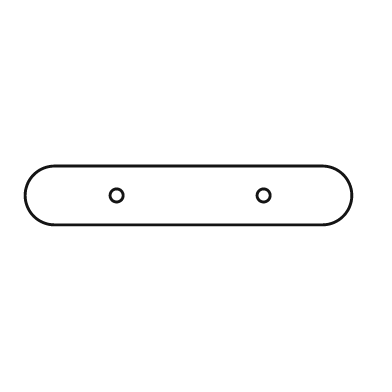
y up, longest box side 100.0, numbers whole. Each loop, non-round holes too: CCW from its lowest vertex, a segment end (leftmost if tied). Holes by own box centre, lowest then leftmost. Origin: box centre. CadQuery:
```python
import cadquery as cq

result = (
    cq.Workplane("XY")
    .moveTo(-41.0, -9.0)
    .lineTo(41.0, -9.0)
    .threePointArc((50.0, 0.0), (41.0, 9.0))
    .lineTo(-41.0, 9.0)
    .threePointArc((-50.0, 0.0), (-41.0, -9.0))
    .close()
    .moveTo(-22.0, 0.0)
    .circle(2.0)
    .moveTo(23.0, 0.0)
    .circle(2.0)
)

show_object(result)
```